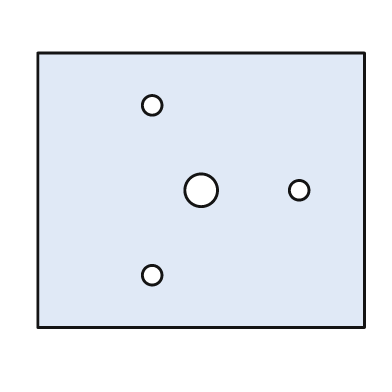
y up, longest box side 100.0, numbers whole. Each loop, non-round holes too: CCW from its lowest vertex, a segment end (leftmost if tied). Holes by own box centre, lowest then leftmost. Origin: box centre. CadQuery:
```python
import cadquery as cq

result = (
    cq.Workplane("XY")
    .moveTo(-50.0, -42.0)
    .lineTo(50.0, -42.0)
    .lineTo(50.0, 42.0)
    .lineTo(-50.0, 42.0)
    .close()
    .moveTo(-15.0, -26.0)
    .circle(3.0)
    .moveTo(0.0, 0.0)
    .circle(5.0)
    .moveTo(30.0, 0.0)
    .circle(3.0)
    .moveTo(-15.0, 26.0)
    .circle(3.0)
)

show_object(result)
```